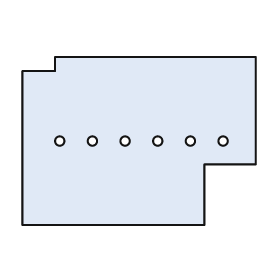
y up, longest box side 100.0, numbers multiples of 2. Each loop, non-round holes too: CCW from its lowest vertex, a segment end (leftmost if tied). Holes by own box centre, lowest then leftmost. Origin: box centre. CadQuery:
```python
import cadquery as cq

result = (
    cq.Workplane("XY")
    .moveTo(-50.0, -36.0)
    .lineTo(28.0, -36.0)
    .lineTo(28.0, -10.0)
    .lineTo(50.0, -10.0)
    .lineTo(50.0, 36.0)
    .lineTo(-36.0, 36.0)
    .lineTo(-36.0, 30.0)
    .lineTo(-50.0, 30.0)
    .close()
    .moveTo(-34.0, 0.0)
    .circle(2.0)
    .moveTo(-20.0, 0.0)
    .circle(2.0)
    .moveTo(-6.0, 0.0)
    .circle(2.0)
    .moveTo(8.0, 0.0)
    .circle(2.0)
    .moveTo(22.0, 0.0)
    .circle(2.0)
    .moveTo(36.0, 0.0)
    .circle(2.0)
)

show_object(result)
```